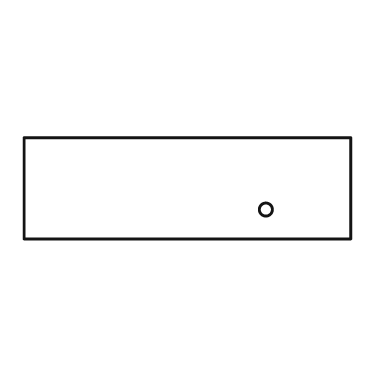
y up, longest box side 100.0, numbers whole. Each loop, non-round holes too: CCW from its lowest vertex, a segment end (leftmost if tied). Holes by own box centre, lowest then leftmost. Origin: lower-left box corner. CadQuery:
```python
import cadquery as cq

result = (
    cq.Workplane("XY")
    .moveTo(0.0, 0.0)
    .lineTo(100.0, 0.0)
    .lineTo(100.0, 31.0)
    .lineTo(0.0, 31.0)
    .close()
    .moveTo(74.0, 9.0)
    .circle(2.0)
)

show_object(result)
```